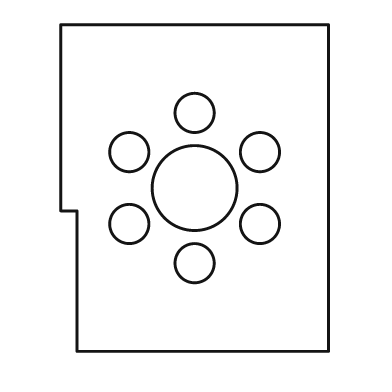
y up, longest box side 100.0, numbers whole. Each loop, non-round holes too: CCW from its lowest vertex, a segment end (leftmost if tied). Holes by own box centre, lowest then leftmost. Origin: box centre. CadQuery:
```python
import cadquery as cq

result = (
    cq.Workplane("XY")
    .moveTo(-36.0, -50.0)
    .lineTo(41.0, -50.0)
    .lineTo(41.0, 50.0)
    .lineTo(-41.0, 50.0)
    .lineTo(-41.0, -7.0)
    .lineTo(-36.0, -7.0)
    .close()
    .moveTo(0.0, -23.0)
    .circle(6.0)
    .moveTo(-20.0, -11.0)
    .circle(6.0)
    .moveTo(20.0, -11.0)
    .circle(6.0)
    .moveTo(0.0, 0.0)
    .circle(13.0)
    .moveTo(-20.0, 11.0)
    .circle(6.0)
    .moveTo(20.0, 11.0)
    .circle(6.0)
    .moveTo(0.0, 23.0)
    .circle(6.0)
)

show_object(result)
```